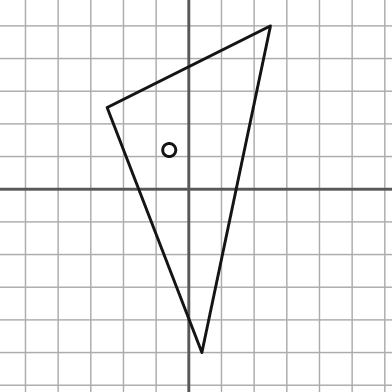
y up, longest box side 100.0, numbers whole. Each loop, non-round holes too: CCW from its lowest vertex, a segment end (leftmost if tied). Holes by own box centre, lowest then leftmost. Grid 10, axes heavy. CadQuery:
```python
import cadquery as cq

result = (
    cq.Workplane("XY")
    .moveTo(4.0, -50.0)
    .lineTo(25.0, 50.0)
    .lineTo(-25.0, 25.0)
    .close()
    .moveTo(-6.0, 12.0)
    .circle(2.0)
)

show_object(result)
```